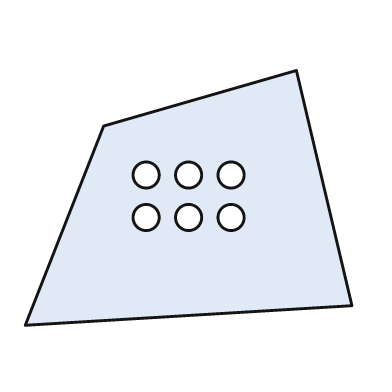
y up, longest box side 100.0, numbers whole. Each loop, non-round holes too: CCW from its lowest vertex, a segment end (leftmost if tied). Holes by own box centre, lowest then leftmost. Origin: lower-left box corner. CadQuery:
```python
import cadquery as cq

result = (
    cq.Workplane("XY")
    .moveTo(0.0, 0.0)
    .lineTo(100.0, 6.0)
    .lineTo(83.0, 78.0)
    .lineTo(24.0, 61.0)
    .close()
    .moveTo(37.0, 33.0)
    .circle(4.0)
    .moveTo(50.0, 33.0)
    .circle(4.0)
    .moveTo(63.0, 33.0)
    .circle(4.0)
    .moveTo(37.0, 46.0)
    .circle(4.0)
    .moveTo(50.0, 46.0)
    .circle(4.0)
    .moveTo(63.0, 46.0)
    .circle(4.0)
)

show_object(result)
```